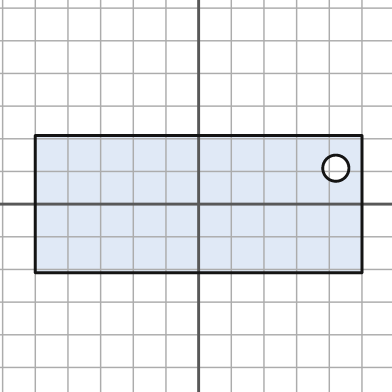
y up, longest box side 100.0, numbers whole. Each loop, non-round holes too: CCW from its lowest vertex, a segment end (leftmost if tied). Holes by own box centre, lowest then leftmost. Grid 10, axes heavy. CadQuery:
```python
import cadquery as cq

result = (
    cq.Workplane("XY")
    .moveTo(-50.0, -21.0)
    .lineTo(50.0, -21.0)
    .lineTo(50.0, 21.0)
    .lineTo(-50.0, 21.0)
    .close()
    .moveTo(42.0, 11.0)
    .circle(4.0)
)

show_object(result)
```